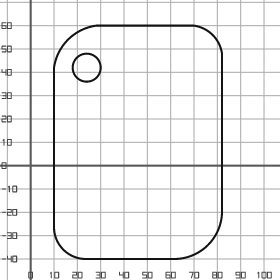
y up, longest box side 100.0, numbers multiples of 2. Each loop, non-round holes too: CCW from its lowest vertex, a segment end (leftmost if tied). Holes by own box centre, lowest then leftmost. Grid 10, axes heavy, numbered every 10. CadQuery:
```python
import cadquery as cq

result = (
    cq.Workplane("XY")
    .moveTo(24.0, -40.0)
    .lineTo(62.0, -40.0)
    .threePointArc((76.0, -34.0), (82.0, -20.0))
    .lineTo(82.0, 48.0)
    .threePointArc((78.0, 56.0), (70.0, 60.0))
    .lineTo(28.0, 60.0)
    .threePointArc((16.0, 54.0), (10.0, 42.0))
    .lineTo(10.0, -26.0)
    .threePointArc((14.0, -36.0), (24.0, -40.0))
    .close()
    .moveTo(24.0, 42.0)
    .circle(6.0)
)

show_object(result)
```